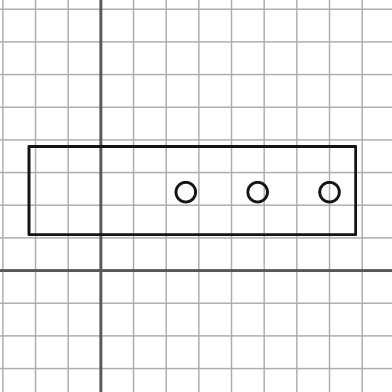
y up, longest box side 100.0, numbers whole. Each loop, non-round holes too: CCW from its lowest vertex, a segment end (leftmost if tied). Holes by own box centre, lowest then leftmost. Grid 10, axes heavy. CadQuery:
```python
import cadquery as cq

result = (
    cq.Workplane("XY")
    .moveTo(-22.0, 11.0)
    .lineTo(78.0, 11.0)
    .lineTo(78.0, 38.0)
    .lineTo(-22.0, 38.0)
    .close()
    .moveTo(26.0, 24.0)
    .circle(3.0)
    .moveTo(48.0, 24.0)
    .circle(3.0)
    .moveTo(70.0, 24.0)
    .circle(3.0)
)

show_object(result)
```